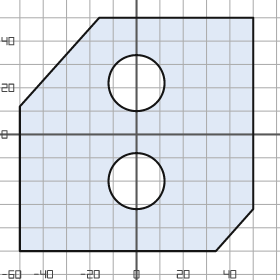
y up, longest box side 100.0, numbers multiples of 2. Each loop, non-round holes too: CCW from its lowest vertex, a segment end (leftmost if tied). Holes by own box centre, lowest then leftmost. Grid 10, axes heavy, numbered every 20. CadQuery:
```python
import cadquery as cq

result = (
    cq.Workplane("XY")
    .moveTo(-50.0, -50.0)
    .lineTo(34.0, -50.0)
    .lineTo(50.0, -32.0)
    .lineTo(50.0, 50.0)
    .lineTo(-16.0, 50.0)
    .lineTo(-50.0, 12.0)
    .close()
    .moveTo(0.0, -20.0)
    .circle(12.0)
    .moveTo(0.0, 22.0)
    .circle(12.0)
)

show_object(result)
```